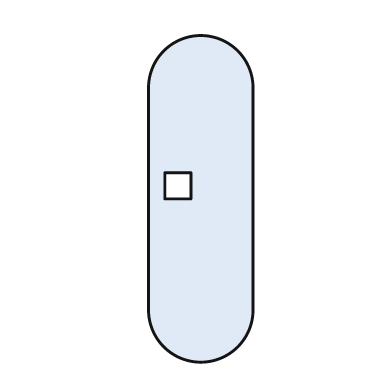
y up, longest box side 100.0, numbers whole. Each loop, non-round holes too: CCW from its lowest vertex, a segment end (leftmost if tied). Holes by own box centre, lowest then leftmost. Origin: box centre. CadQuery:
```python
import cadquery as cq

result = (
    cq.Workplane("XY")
    .moveTo(-16.0, -34.0)
    .threePointArc((0.0, -50.0), (16.0, -34.0))
    .lineTo(16.0, 34.0)
    .threePointArc((0.0, 50.0), (-16.0, 34.0))
    .close()
    .moveTo(-11.0, 0.0)
    .lineTo(-3.0, 0.0)
    .lineTo(-3.0, 8.0)
    .lineTo(-11.0, 8.0)
    .close()
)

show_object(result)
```